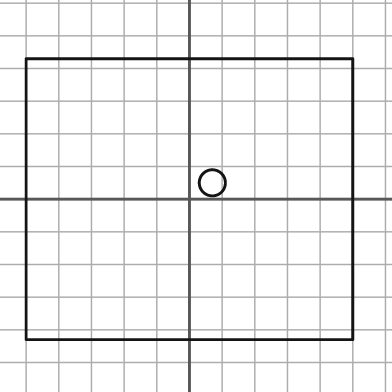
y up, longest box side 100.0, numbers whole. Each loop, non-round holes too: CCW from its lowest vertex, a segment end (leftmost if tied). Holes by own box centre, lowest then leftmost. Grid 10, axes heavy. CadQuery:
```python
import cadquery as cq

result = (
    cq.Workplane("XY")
    .moveTo(-50.0, -43.0)
    .lineTo(50.0, -43.0)
    .lineTo(50.0, 43.0)
    .lineTo(-50.0, 43.0)
    .close()
    .moveTo(7.0, 5.0)
    .circle(4.0)
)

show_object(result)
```